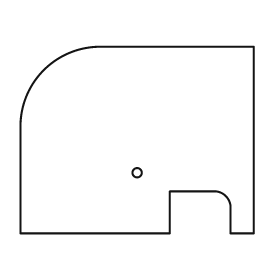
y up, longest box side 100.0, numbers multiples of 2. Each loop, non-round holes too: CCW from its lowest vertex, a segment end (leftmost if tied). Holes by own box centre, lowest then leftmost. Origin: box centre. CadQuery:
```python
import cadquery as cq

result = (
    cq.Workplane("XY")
    .moveTo(-50.0, -40.0)
    .lineTo(14.0, -40.0)
    .lineTo(14.0, -22.0)
    .lineTo(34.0, -22.0)
    .threePointArc((38.0, -24.0), (40.0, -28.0))
    .lineTo(40.0, -40.0)
    .lineTo(50.0, -40.0)
    .lineTo(50.0, 40.0)
    .lineTo(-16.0, 40.0)
    .threePointArc((-40.0, 30.0), (-50.0, 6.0))
    .close()
    .moveTo(0.0, -14.0)
    .circle(2.0)
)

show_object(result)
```